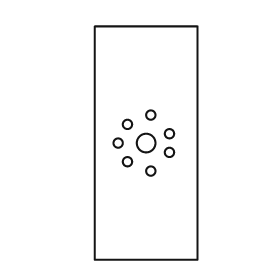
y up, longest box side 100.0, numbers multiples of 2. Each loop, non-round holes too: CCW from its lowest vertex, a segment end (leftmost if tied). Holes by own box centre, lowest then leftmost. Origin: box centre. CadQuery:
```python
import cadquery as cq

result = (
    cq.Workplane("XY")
    .moveTo(-22.0, -50.0)
    .lineTo(22.0, -50.0)
    .lineTo(22.0, 50.0)
    .lineTo(-22.0, 50.0)
    .close()
    .moveTo(2.0, -12.0)
    .circle(2.0)
    .moveTo(-8.0, -8.0)
    .circle(2.0)
    .moveTo(10.0, -4.0)
    .circle(2.0)
    .moveTo(-12.0, 0.0)
    .circle(2.0)
    .moveTo(0.0, 0.0)
    .circle(4.0)
    .moveTo(10.0, 4.0)
    .circle(2.0)
    .moveTo(-8.0, 8.0)
    .circle(2.0)
    .moveTo(2.0, 12.0)
    .circle(2.0)
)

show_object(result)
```